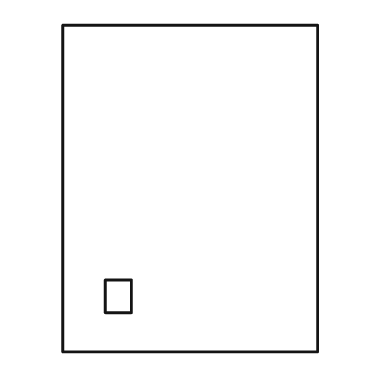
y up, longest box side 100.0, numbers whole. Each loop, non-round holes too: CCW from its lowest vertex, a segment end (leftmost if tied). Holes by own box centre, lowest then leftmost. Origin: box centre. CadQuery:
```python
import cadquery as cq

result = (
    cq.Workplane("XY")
    .moveTo(-39.0, -50.0)
    .lineTo(39.0, -50.0)
    .lineTo(39.0, 50.0)
    .lineTo(-39.0, 50.0)
    .close()
    .moveTo(-26.0, -38.0)
    .lineTo(-18.0, -38.0)
    .lineTo(-18.0, -28.0)
    .lineTo(-26.0, -28.0)
    .close()
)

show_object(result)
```